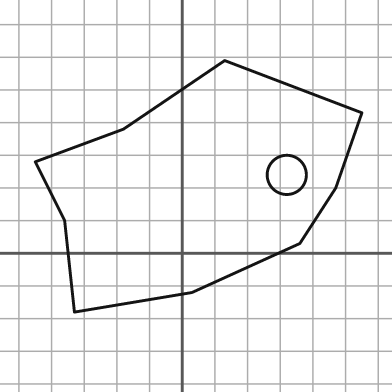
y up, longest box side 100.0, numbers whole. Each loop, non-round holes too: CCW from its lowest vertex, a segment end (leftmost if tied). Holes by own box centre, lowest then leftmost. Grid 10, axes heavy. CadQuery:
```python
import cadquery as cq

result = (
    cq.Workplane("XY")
    .moveTo(-33.0, -18.0)
    .lineTo(3.0, -12.0)
    .lineTo(36.0, 3.0)
    .lineTo(47.0, 20.0)
    .lineTo(55.0, 43.0)
    .lineTo(13.0, 59.0)
    .lineTo(-18.0, 38.0)
    .lineTo(-45.0, 28.0)
    .lineTo(-36.0, 10.0)
    .close()
    .moveTo(32.0, 24.0)
    .circle(6.0)
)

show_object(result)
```